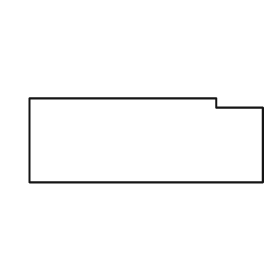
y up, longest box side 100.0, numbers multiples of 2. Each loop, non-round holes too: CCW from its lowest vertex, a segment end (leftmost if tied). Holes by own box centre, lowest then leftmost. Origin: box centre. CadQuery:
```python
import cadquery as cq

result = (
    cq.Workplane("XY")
    .moveTo(-50.0, -18.0)
    .lineTo(50.0, -18.0)
    .lineTo(50.0, 14.0)
    .lineTo(30.0, 14.0)
    .lineTo(30.0, 18.0)
    .lineTo(-50.0, 18.0)
    .close()
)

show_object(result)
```